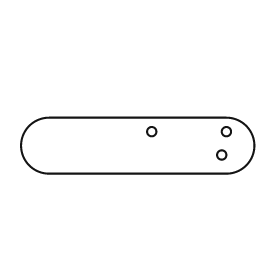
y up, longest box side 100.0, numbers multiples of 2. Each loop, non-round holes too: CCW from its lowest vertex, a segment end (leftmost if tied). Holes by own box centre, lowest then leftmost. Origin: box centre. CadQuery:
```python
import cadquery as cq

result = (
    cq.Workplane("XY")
    .moveTo(-38.0, -12.0)
    .lineTo(38.0, -12.0)
    .threePointArc((50.0, 0.0), (38.0, 12.0))
    .lineTo(-38.0, 12.0)
    .threePointArc((-50.0, 0.0), (-38.0, -12.0))
    .close()
    .moveTo(36.0, -4.0)
    .circle(2.0)
    .moveTo(6.0, 6.0)
    .circle(2.0)
    .moveTo(38.0, 6.0)
    .circle(2.0)
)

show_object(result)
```